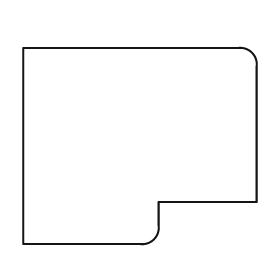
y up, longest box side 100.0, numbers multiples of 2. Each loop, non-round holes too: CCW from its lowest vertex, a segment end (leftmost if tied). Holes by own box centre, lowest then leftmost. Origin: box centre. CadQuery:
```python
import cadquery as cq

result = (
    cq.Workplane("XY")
    .moveTo(-50.0, -42.0)
    .lineTo(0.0, -42.0)
    .threePointArc((6.0, -40.0), (8.0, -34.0))
    .lineTo(8.0, -24.0)
    .lineTo(50.0, -24.0)
    .lineTo(50.0, 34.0)
    .threePointArc((48.0, 40.0), (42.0, 42.0))
    .lineTo(-50.0, 42.0)
    .close()
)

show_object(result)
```